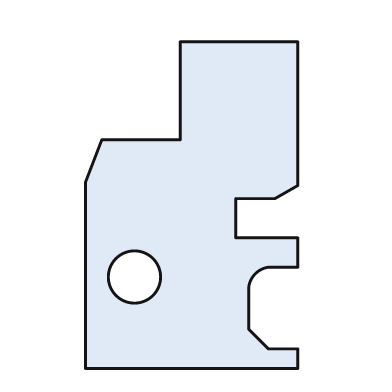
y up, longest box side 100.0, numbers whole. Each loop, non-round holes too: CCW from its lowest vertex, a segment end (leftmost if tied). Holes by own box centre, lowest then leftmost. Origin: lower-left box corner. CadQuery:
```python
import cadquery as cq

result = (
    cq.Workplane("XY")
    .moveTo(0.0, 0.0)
    .lineTo(65.0, 0.0)
    .lineTo(65.0, 6.0)
    .lineTo(56.0, 6.0)
    .lineTo(50.0, 12.0)
    .lineTo(50.0, 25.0)
    .threePointArc((52.0, 29.0), (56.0, 31.0))
    .lineTo(65.0, 31.0)
    .lineTo(65.0, 40.0)
    .lineTo(46.0, 40.0)
    .lineTo(46.0, 52.0)
    .lineTo(58.0, 52.0)
    .lineTo(65.0, 56.0)
    .lineTo(65.0, 100.0)
    .lineTo(29.0, 100.0)
    .lineTo(29.0, 70.0)
    .lineTo(5.0, 70.0)
    .lineTo(0.0, 57.0)
    .close()
    .moveTo(15.0, 28.0)
    .circle(8.0)
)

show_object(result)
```